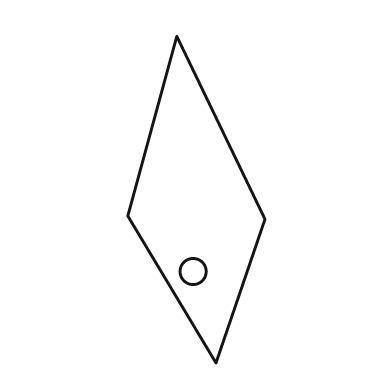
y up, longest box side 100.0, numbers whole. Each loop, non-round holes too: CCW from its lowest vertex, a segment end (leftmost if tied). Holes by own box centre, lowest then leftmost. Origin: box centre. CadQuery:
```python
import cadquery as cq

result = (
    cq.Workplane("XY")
    .moveTo(6.0, -50.0)
    .lineTo(21.0, -6.0)
    .lineTo(-6.0, 50.0)
    .lineTo(-21.0, -5.0)
    .close()
    .moveTo(-1.0, -22.0)
    .circle(4.0)
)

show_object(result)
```